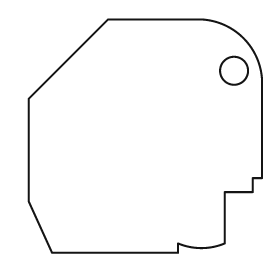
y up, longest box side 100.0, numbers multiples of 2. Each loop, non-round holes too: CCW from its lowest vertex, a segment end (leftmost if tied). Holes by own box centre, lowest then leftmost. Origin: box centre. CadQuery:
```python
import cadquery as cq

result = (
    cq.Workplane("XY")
    .moveTo(-40.0, -50.0)
    .lineTo(14.0, -50.0)
    .lineTo(14.0, -46.0)
    .threePointArc((24.0, -48.0), (34.0, -46.0))
    .lineTo(34.0, -24.0)
    .lineTo(46.0, -24.0)
    .lineTo(46.0, -18.0)
    .lineTo(50.0, -18.0)
    .lineTo(50.0, 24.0)
    .threePointArc((42.0, 42.0), (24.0, 50.0))
    .lineTo(-16.0, 50.0)
    .lineTo(-50.0, 16.0)
    .lineTo(-50.0, -28.0)
    .close()
    .moveTo(38.0, 28.0)
    .circle(6.0)
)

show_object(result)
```